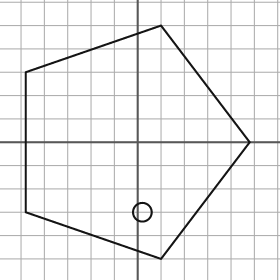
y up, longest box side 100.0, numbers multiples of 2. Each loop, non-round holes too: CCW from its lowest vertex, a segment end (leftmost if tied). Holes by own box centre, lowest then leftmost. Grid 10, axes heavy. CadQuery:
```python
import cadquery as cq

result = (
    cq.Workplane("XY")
    .moveTo(10.0, -50.0)
    .lineTo(48.0, 0.0)
    .lineTo(10.0, 50.0)
    .lineTo(-48.0, 30.0)
    .lineTo(-48.0, -30.0)
    .close()
    .moveTo(2.0, -30.0)
    .circle(4.0)
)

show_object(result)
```